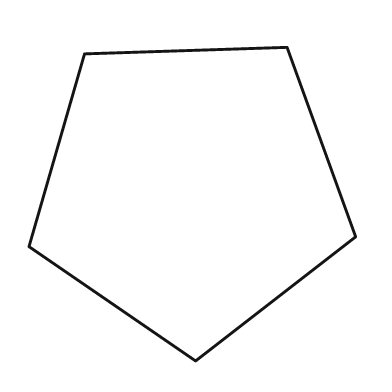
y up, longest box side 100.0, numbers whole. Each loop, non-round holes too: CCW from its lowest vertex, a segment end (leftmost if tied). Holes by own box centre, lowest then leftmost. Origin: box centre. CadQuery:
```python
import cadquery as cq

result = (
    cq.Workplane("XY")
    .moveTo(1.0, -48.0)
    .lineTo(50.0, -10.0)
    .lineTo(29.0, 48.0)
    .lineTo(-33.0, 46.0)
    .lineTo(-50.0, -13.0)
    .close()
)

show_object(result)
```